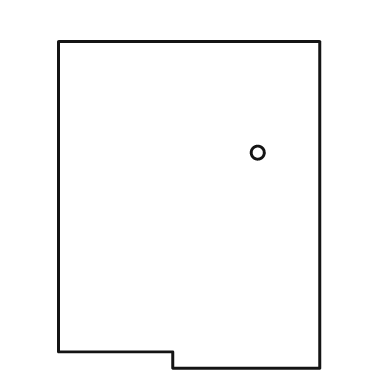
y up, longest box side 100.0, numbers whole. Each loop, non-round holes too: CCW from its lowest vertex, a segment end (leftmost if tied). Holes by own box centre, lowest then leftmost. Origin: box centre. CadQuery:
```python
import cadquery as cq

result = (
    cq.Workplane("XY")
    .moveTo(-5.0, -50.0)
    .lineTo(40.0, -50.0)
    .lineTo(40.0, 50.0)
    .lineTo(-40.0, 50.0)
    .lineTo(-40.0, -45.0)
    .lineTo(-5.0, -45.0)
    .close()
    .moveTo(21.0, 16.0)
    .circle(2.0)
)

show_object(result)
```